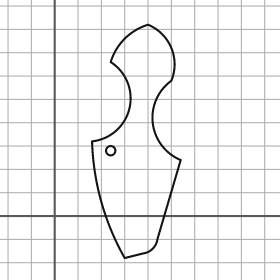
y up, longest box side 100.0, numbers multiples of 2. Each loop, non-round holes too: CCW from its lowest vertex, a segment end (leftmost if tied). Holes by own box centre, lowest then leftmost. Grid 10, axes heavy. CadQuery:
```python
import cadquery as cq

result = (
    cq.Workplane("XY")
    .moveTo(30.0, -18.0)
    .lineTo(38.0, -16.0)
    .threePointArc((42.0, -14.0), (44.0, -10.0))
    .lineTo(54.0, 24.0)
    .threePointArc((42.0, 40.0), (50.0, 58.0))
    .threePointArc((50.0, 72.0), (40.0, 82.0))
    .threePointArc((30.0, 76.0), (24.0, 66.0))
    .threePointArc((32.0, 46.0), (16.0, 32.0))
    .threePointArc((20.0, 6.0), (30.0, -18.0))
    .close()
    .moveTo(24.0, 28.0)
    .circle(2.0)
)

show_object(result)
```